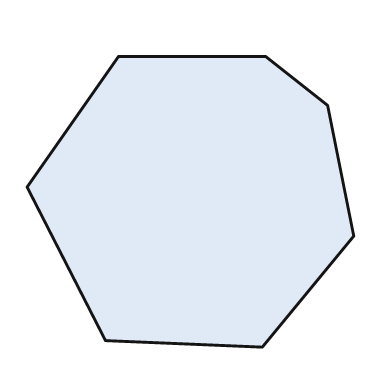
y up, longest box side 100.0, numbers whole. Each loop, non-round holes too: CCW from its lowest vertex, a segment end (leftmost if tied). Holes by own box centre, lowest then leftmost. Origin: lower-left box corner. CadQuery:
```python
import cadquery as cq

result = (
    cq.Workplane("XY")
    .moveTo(72.0, 0.0)
    .lineTo(100.0, 34.0)
    .lineTo(92.0, 74.0)
    .lineTo(73.0, 89.0)
    .lineTo(28.0, 89.0)
    .lineTo(0.0, 49.0)
    .lineTo(24.0, 2.0)
    .close()
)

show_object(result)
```